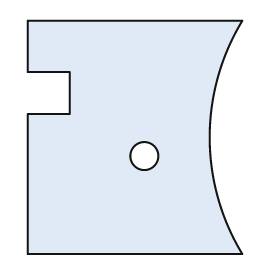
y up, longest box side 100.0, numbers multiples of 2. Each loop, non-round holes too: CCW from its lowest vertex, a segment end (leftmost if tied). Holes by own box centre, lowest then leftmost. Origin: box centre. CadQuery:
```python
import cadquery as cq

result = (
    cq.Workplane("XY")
    .moveTo(-46.0, -50.0)
    .lineTo(46.0, -50.0)
    .threePointArc((32.0, 0.0), (46.0, 50.0))
    .lineTo(-46.0, 50.0)
    .lineTo(-46.0, 28.0)
    .lineTo(-28.0, 28.0)
    .lineTo(-28.0, 10.0)
    .lineTo(-46.0, 10.0)
    .close()
    .moveTo(4.0, -8.0)
    .circle(6.0)
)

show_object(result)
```